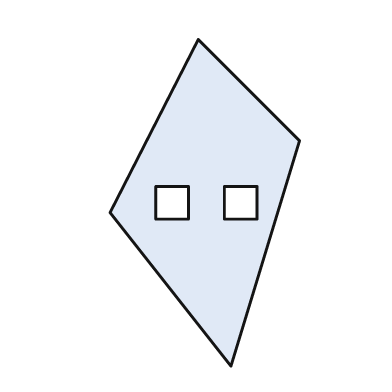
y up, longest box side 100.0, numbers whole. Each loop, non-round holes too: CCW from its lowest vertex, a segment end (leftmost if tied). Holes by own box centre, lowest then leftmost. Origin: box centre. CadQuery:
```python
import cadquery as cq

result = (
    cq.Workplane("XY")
    .moveTo(8.0, -50.0)
    .lineTo(29.0, 19.0)
    .lineTo(-2.0, 50.0)
    .lineTo(-29.0, -3.0)
    .close()
    .moveTo(-15.0, -5.0)
    .lineTo(-5.0, -5.0)
    .lineTo(-5.0, 5.0)
    .lineTo(-15.0, 5.0)
    .close()
    .moveTo(6.0, -5.0)
    .lineTo(16.0, -5.0)
    .lineTo(16.0, 5.0)
    .lineTo(6.0, 5.0)
    .close()
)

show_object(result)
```